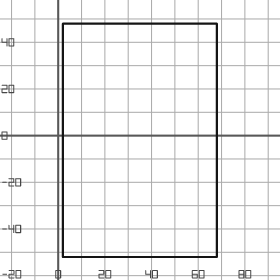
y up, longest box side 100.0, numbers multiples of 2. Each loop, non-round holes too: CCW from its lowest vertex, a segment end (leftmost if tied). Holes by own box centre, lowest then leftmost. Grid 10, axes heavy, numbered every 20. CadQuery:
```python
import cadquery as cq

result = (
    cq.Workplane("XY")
    .moveTo(2.0, -52.0)
    .lineTo(68.0, -52.0)
    .lineTo(68.0, 48.0)
    .lineTo(2.0, 48.0)
    .close()
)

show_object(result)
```